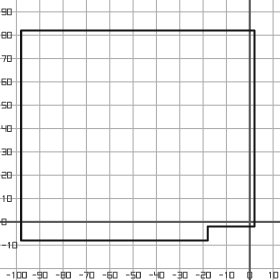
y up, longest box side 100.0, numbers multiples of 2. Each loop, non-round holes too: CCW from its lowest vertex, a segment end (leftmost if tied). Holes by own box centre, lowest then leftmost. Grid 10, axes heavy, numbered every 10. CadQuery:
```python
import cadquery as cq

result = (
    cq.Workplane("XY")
    .moveTo(-98.0, -8.0)
    .lineTo(-18.0, -8.0)
    .lineTo(-18.0, -2.0)
    .lineTo(2.0, -2.0)
    .lineTo(2.0, 82.0)
    .lineTo(-98.0, 82.0)
    .close()
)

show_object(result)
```